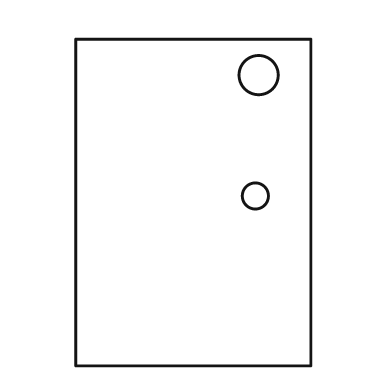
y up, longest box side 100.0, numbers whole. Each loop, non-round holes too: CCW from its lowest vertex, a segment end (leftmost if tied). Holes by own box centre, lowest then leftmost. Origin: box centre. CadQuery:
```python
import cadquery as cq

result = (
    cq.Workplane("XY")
    .moveTo(-36.0, -50.0)
    .lineTo(36.0, -50.0)
    .lineTo(36.0, 50.0)
    .lineTo(-36.0, 50.0)
    .close()
    .moveTo(19.0, 2.0)
    .circle(4.0)
    .moveTo(20.0, 39.0)
    .circle(6.0)
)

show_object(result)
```